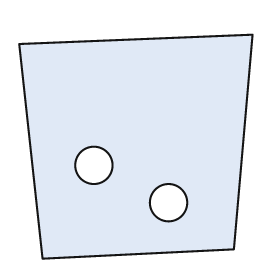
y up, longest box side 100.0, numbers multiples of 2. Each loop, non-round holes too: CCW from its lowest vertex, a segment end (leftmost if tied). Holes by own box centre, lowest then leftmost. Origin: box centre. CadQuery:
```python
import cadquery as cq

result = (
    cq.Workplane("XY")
    .moveTo(-40.0, -48.0)
    .lineTo(42.0, -44.0)
    .lineTo(50.0, 48.0)
    .lineTo(-50.0, 44.0)
    .close()
    .moveTo(14.0, -24.0)
    .circle(8.0)
    .moveTo(-18.0, -8.0)
    .circle(8.0)
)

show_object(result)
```